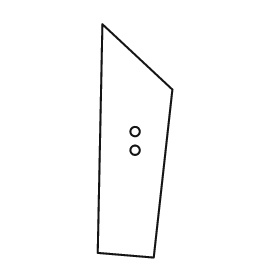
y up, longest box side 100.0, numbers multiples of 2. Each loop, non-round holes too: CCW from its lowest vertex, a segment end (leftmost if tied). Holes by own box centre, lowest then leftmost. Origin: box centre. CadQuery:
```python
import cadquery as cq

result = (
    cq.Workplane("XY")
    .moveTo(8.0, -50.0)
    .lineTo(16.0, 22.0)
    .lineTo(-14.0, 50.0)
    .lineTo(-16.0, -48.0)
    .close()
    .moveTo(0.0, -4.0)
    .circle(2.0)
    .moveTo(0.0, 4.0)
    .circle(2.0)
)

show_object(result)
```